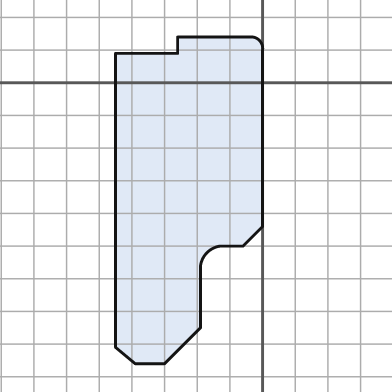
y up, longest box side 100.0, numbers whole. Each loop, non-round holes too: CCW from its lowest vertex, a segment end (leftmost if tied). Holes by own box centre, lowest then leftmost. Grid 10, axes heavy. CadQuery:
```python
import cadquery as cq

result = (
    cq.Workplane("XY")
    .moveTo(-39.0, -86.0)
    .lineTo(-30.0, -86.0)
    .lineTo(-19.0, -75.0)
    .lineTo(-19.0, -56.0)
    .threePointArc((-17.0, -52.0), (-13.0, -50.0))
    .lineTo(-6.0, -50.0)
    .lineTo(0.0, -44.0)
    .lineTo(0.0, 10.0)
    .threePointArc((-1.0, 13.0), (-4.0, 14.0))
    .lineTo(-26.0, 14.0)
    .lineTo(-26.0, 9.0)
    .lineTo(-45.0, 9.0)
    .lineTo(-45.0, -81.0)
    .close()
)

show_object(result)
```